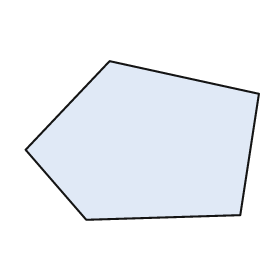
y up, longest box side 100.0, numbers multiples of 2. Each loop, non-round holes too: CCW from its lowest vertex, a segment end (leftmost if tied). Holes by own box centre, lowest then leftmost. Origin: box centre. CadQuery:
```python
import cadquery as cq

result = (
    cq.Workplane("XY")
    .moveTo(-24.0, -34.0)
    .lineTo(42.0, -32.0)
    .lineTo(50.0, 20.0)
    .lineTo(-14.0, 34.0)
    .lineTo(-50.0, -4.0)
    .close()
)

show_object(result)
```